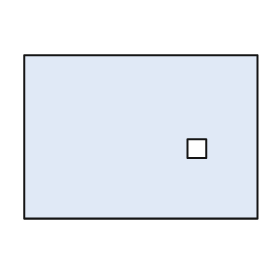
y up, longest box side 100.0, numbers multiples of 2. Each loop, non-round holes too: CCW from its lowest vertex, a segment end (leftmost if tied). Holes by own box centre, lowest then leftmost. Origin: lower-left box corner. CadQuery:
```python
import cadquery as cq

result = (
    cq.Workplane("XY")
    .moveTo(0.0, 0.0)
    .lineTo(100.0, 0.0)
    .lineTo(100.0, 70.0)
    .lineTo(0.0, 70.0)
    .close()
    .moveTo(70.0, 26.0)
    .lineTo(78.0, 26.0)
    .lineTo(78.0, 34.0)
    .lineTo(70.0, 34.0)
    .close()
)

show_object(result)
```